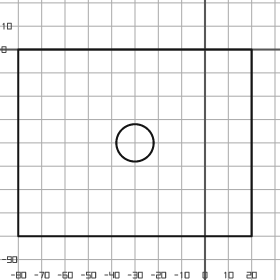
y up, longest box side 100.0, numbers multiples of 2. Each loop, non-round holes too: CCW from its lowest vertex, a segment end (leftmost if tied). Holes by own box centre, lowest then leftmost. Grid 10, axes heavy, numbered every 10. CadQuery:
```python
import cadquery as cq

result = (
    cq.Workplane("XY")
    .moveTo(-80.0, -80.0)
    .lineTo(20.0, -80.0)
    .lineTo(20.0, 0.0)
    .lineTo(-80.0, 0.0)
    .close()
    .moveTo(-30.0, -40.0)
    .circle(8.0)
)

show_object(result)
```